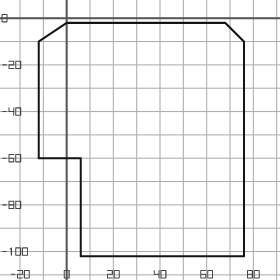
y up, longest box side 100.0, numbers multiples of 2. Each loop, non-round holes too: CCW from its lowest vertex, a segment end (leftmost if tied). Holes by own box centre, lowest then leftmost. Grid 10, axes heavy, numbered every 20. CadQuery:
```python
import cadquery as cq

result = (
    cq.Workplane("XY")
    .moveTo(6.0, -102.0)
    .lineTo(76.0, -102.0)
    .lineTo(76.0, -10.0)
    .lineTo(68.0, -2.0)
    .lineTo(0.0, -2.0)
    .lineTo(-12.0, -10.0)
    .lineTo(-12.0, -60.0)
    .lineTo(6.0, -60.0)
    .close()
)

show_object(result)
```